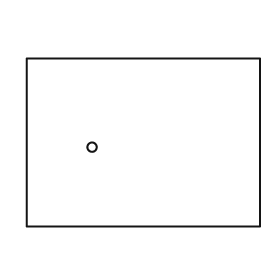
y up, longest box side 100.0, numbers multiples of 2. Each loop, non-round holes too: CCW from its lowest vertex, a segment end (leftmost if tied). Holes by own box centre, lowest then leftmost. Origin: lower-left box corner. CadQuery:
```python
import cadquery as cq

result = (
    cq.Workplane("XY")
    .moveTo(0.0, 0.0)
    .lineTo(100.0, 0.0)
    .lineTo(100.0, 72.0)
    .lineTo(0.0, 72.0)
    .close()
    .moveTo(28.0, 34.0)
    .circle(2.0)
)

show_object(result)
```